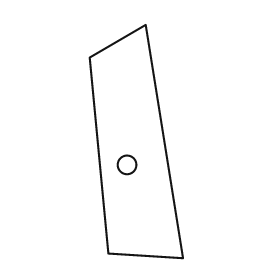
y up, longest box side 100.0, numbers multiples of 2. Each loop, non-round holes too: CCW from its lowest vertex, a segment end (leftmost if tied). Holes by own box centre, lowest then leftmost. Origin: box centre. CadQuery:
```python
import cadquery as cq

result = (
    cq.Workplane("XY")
    .moveTo(20.0, -50.0)
    .lineTo(4.0, 50.0)
    .lineTo(-20.0, 36.0)
    .lineTo(-12.0, -48.0)
    .close()
    .moveTo(-4.0, -10.0)
    .circle(4.0)
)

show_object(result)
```